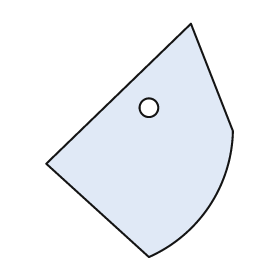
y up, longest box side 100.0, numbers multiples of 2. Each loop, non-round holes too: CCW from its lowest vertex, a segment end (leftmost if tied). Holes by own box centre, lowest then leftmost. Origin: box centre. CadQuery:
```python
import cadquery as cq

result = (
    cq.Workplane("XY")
    .moveTo(4.0, -50.0)
    .threePointArc((30.0, -28.0), (40.0, 4.0))
    .lineTo(22.0, 50.0)
    .lineTo(-40.0, -10.0)
    .close()
    .moveTo(4.0, 14.0)
    .circle(4.0)
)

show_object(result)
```